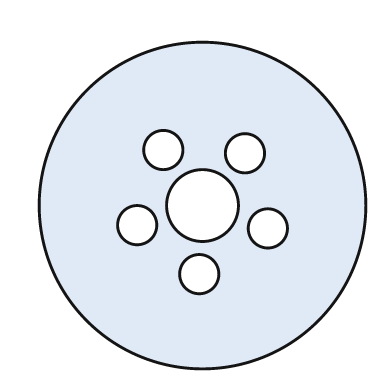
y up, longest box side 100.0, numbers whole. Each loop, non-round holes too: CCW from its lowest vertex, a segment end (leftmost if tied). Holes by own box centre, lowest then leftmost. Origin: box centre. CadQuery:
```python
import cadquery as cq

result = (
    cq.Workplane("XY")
    .moveTo(0.0, 0.0)
    .circle(50.0)
    .moveTo(-1.0, -21.0)
    .circle(6.0)
    .moveTo(20.0, -7.0)
    .circle(6.0)
    .moveTo(-20.0, -6.0)
    .circle(6.0)
    .moveTo(0.0, 0.0)
    .circle(11.0)
    .moveTo(13.0, 16.0)
    .circle(6.0)
    .moveTo(-12.0, 17.0)
    .circle(6.0)
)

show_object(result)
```